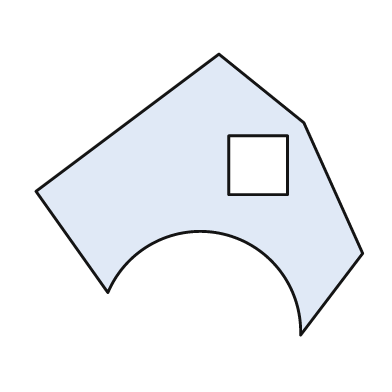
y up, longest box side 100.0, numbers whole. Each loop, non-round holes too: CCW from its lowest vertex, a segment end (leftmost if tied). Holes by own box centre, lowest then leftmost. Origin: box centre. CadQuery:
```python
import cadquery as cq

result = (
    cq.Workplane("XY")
    .moveTo(31.0, -43.0)
    .lineTo(50.0, -18.0)
    .lineTo(32.0, 22.0)
    .lineTo(6.0, 43.0)
    .lineTo(-50.0, 1.0)
    .lineTo(-28.0, -30.0)
    .threePointArc((7.0, -12.0), (31.0, -43.0))
    .close()
    .moveTo(9.0, 0.0)
    .lineTo(27.0, 0.0)
    .lineTo(27.0, 18.0)
    .lineTo(9.0, 18.0)
    .close()
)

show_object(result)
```